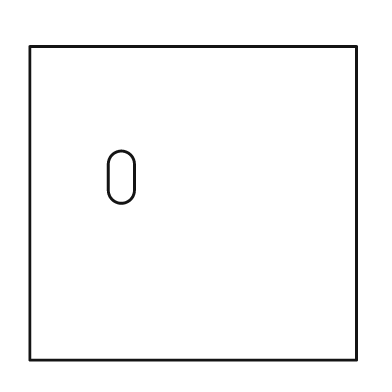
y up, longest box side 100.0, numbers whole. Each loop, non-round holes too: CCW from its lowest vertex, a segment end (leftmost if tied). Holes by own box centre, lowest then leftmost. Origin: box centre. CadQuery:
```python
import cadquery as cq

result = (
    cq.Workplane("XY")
    .moveTo(-50.0, -48.0)
    .lineTo(50.0, -48.0)
    .lineTo(50.0, 48.0)
    .lineTo(-50.0, 48.0)
    .close()
    .moveTo(-26.0, 4.0)
    .threePointArc((-22.0, 0.0), (-18.0, 4.0))
    .lineTo(-18.0, 12.0)
    .threePointArc((-22.0, 16.0), (-26.0, 12.0))
    .close()
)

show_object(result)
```